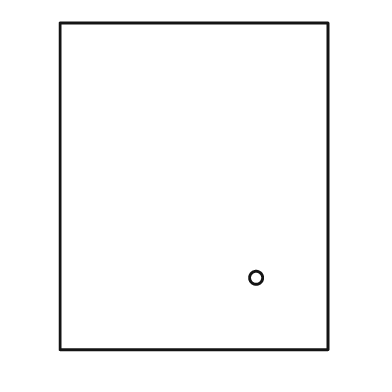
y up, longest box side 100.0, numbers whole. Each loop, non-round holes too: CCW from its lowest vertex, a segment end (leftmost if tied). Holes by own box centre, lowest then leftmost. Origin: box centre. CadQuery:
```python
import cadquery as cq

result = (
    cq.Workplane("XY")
    .moveTo(-41.0, -50.0)
    .lineTo(41.0, -50.0)
    .lineTo(41.0, 50.0)
    .lineTo(-41.0, 50.0)
    .close()
    .moveTo(19.0, -28.0)
    .circle(2.0)
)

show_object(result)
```